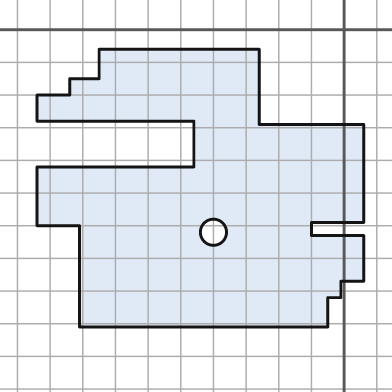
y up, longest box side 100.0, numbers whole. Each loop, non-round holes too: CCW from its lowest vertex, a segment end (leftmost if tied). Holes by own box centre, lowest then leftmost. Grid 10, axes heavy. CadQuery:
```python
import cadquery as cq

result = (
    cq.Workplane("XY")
    .moveTo(-81.0, -91.0)
    .lineTo(-5.0, -91.0)
    .lineTo(-5.0, -82.0)
    .lineTo(-1.0, -82.0)
    .lineTo(-1.0, -77.0)
    .lineTo(6.0, -77.0)
    .lineTo(6.0, -63.0)
    .lineTo(-10.0, -63.0)
    .lineTo(-10.0, -59.0)
    .lineTo(6.0, -59.0)
    .lineTo(6.0, -29.0)
    .lineTo(-26.0, -29.0)
    .lineTo(-26.0, -6.0)
    .lineTo(-75.0, -6.0)
    .lineTo(-75.0, -15.0)
    .lineTo(-84.0, -15.0)
    .lineTo(-84.0, -20.0)
    .lineTo(-94.0, -20.0)
    .lineTo(-94.0, -28.0)
    .lineTo(-46.0, -28.0)
    .lineTo(-46.0, -42.0)
    .lineTo(-94.0, -42.0)
    .lineTo(-94.0, -60.0)
    .lineTo(-81.0, -60.0)
    .close()
    .moveTo(-40.0, -62.0)
    .circle(4.0)
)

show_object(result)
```